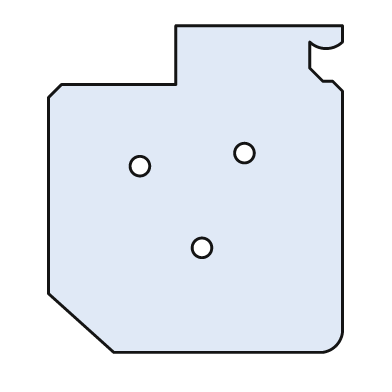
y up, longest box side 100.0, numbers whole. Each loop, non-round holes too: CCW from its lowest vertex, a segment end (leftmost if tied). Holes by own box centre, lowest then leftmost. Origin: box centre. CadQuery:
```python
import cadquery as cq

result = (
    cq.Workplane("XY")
    .moveTo(-25.0, -50.0)
    .lineTo(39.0, -50.0)
    .threePointArc((43.0, -48.0), (45.0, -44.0))
    .lineTo(45.0, 30.0)
    .lineTo(42.0, 33.0)
    .lineTo(39.0, 33.0)
    .lineTo(35.0, 37.0)
    .lineTo(35.0, 45.0)
    .threePointArc((40.0, 43.0), (45.0, 45.0))
    .lineTo(45.0, 50.0)
    .lineTo(-6.0, 50.0)
    .lineTo(-6.0, 32.0)
    .lineTo(-41.0, 32.0)
    .lineTo(-45.0, 28.0)
    .lineTo(-45.0, -32.0)
    .close()
    .moveTo(2.0, -18.0)
    .circle(3.0)
    .moveTo(-17.0, 7.0)
    .circle(3.0)
    .moveTo(15.0, 11.0)
    .circle(3.0)
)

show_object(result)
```